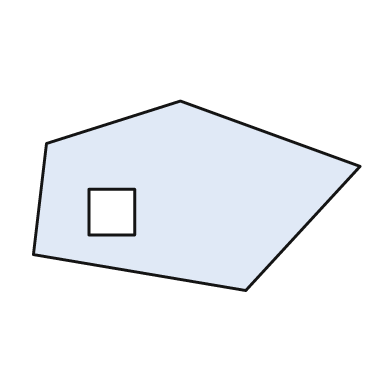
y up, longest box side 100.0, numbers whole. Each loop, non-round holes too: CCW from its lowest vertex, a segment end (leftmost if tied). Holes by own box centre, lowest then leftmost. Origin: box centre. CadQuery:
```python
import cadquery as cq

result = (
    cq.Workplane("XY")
    .moveTo(15.0, -29.0)
    .lineTo(50.0, 9.0)
    .lineTo(-5.0, 29.0)
    .lineTo(-46.0, 16.0)
    .lineTo(-50.0, -18.0)
    .close()
    .moveTo(-33.0, -12.0)
    .lineTo(-19.0, -12.0)
    .lineTo(-19.0, 2.0)
    .lineTo(-33.0, 2.0)
    .close()
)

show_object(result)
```